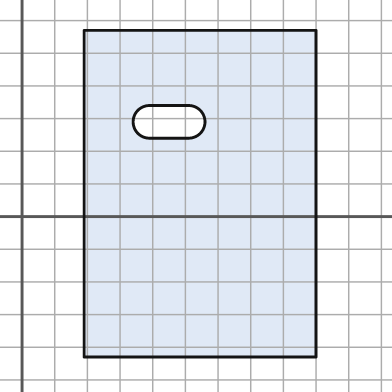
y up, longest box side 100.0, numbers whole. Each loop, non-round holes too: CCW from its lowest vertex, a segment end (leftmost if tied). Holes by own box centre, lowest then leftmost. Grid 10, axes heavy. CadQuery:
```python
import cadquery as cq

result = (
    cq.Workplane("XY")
    .moveTo(19.0, -43.0)
    .lineTo(90.0, -43.0)
    .lineTo(90.0, 57.0)
    .lineTo(19.0, 57.0)
    .close()
    .moveTo(39.0, 24.0)
    .lineTo(51.0, 24.0)
    .threePointArc((56.0, 29.0), (51.0, 34.0))
    .lineTo(39.0, 34.0)
    .threePointArc((34.0, 29.0), (39.0, 24.0))
    .close()
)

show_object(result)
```